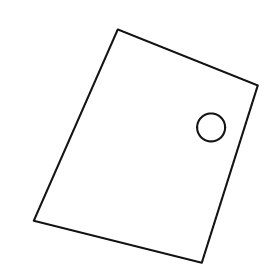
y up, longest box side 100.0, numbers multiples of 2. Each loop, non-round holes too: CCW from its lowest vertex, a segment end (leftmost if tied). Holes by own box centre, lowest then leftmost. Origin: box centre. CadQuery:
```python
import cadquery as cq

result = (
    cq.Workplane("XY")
    .moveTo(24.0, -50.0)
    .lineTo(48.0, 26.0)
    .lineTo(-12.0, 50.0)
    .lineTo(-48.0, -32.0)
    .close()
    .moveTo(28.0, 8.0)
    .circle(6.0)
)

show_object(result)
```